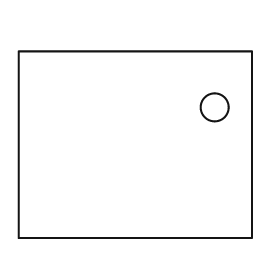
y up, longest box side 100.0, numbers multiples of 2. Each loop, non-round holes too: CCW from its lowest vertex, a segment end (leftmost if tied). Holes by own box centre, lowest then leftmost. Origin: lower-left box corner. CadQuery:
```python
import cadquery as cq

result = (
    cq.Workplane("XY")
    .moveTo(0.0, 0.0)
    .lineTo(100.0, 0.0)
    .lineTo(100.0, 80.0)
    .lineTo(0.0, 80.0)
    .close()
    .moveTo(84.0, 56.0)
    .circle(6.0)
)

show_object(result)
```